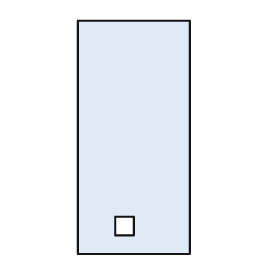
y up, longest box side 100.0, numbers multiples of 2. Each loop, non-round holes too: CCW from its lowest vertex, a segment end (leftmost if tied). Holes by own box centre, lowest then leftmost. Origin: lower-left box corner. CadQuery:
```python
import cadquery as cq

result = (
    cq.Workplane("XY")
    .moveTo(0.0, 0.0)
    .lineTo(48.0, 0.0)
    .lineTo(48.0, 100.0)
    .lineTo(0.0, 100.0)
    .close()
    .moveTo(16.0, 8.0)
    .lineTo(24.0, 8.0)
    .lineTo(24.0, 16.0)
    .lineTo(16.0, 16.0)
    .close()
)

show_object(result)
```